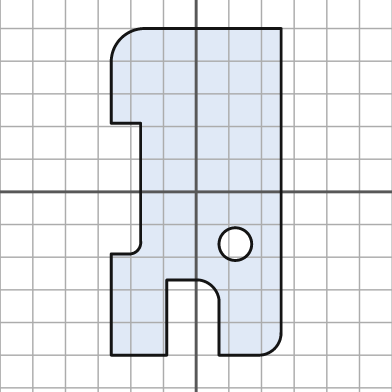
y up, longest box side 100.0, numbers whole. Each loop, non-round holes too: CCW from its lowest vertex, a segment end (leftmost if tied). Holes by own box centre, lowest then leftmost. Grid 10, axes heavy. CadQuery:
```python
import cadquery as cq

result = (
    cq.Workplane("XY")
    .moveTo(-26.0, -50.0)
    .lineTo(-9.0, -50.0)
    .lineTo(-9.0, -27.0)
    .lineTo(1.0, -27.0)
    .threePointArc((5.0, -29.0), (7.0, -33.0))
    .lineTo(7.0, -50.0)
    .lineTo(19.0, -50.0)
    .threePointArc((24.0, -48.0), (26.0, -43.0))
    .lineTo(26.0, 50.0)
    .lineTo(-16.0, 50.0)
    .threePointArc((-23.0, 47.0), (-26.0, 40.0))
    .lineTo(-26.0, 21.0)
    .lineTo(-17.0, 21.0)
    .lineTo(-17.0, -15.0)
    .threePointArc((-18.0, -18.0), (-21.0, -19.0))
    .lineTo(-26.0, -19.0)
    .close()
    .moveTo(12.0, -16.0)
    .circle(5.0)
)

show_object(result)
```